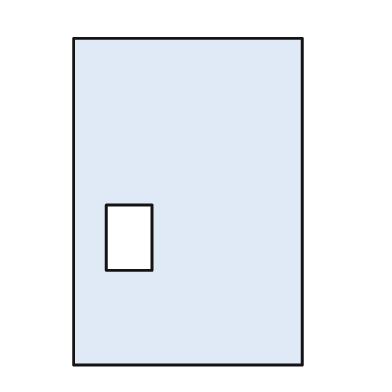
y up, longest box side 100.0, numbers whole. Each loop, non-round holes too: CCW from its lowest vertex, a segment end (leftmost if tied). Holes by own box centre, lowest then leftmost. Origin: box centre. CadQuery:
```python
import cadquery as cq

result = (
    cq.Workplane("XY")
    .moveTo(-35.0, -50.0)
    .lineTo(35.0, -50.0)
    .lineTo(35.0, 50.0)
    .lineTo(-35.0, 50.0)
    .close()
    .moveTo(-25.0, -21.0)
    .lineTo(-11.0, -21.0)
    .lineTo(-11.0, -1.0)
    .lineTo(-25.0, -1.0)
    .close()
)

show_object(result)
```